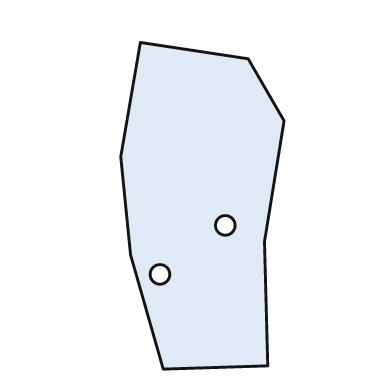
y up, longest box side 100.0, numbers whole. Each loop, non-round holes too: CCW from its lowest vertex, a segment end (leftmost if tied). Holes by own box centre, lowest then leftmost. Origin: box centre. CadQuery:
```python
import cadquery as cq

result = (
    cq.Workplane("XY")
    .moveTo(-12.0, -50.0)
    .lineTo(20.0, -49.0)
    .lineTo(19.0, -11.0)
    .lineTo(25.0, 26.0)
    .lineTo(14.0, 45.0)
    .lineTo(-19.0, 50.0)
    .lineTo(-25.0, 15.0)
    .lineTo(-22.0, -15.0)
    .close()
    .moveTo(-13.0, -21.0)
    .circle(3.0)
    .moveTo(7.0, -6.0)
    .circle(3.0)
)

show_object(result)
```